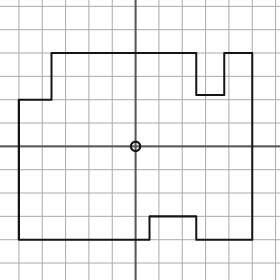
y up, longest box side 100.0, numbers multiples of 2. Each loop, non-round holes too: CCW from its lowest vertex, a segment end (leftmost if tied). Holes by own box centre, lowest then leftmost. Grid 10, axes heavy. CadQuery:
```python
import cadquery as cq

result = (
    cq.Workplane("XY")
    .moveTo(-50.0, -40.0)
    .lineTo(6.0, -40.0)
    .lineTo(6.0, -30.0)
    .lineTo(26.0, -30.0)
    .lineTo(26.0, -40.0)
    .lineTo(50.0, -40.0)
    .lineTo(50.0, 40.0)
    .lineTo(38.0, 40.0)
    .lineTo(38.0, 22.0)
    .lineTo(26.0, 22.0)
    .lineTo(26.0, 40.0)
    .lineTo(-36.0, 40.0)
    .lineTo(-36.0, 20.0)
    .lineTo(-50.0, 20.0)
    .close()
    .moveTo(0.0, 0.0)
    .circle(2.0)
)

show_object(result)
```